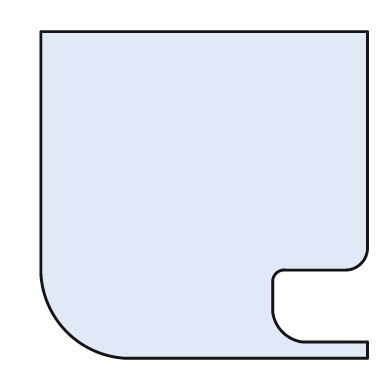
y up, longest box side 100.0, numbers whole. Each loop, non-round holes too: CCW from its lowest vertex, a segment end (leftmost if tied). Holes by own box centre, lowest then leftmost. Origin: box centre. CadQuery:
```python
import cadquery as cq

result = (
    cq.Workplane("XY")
    .moveTo(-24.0, -50.0)
    .lineTo(50.0, -50.0)
    .lineTo(50.0, -45.0)
    .lineTo(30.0, -45.0)
    .threePointArc((24.0, -42.0), (21.0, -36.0))
    .lineTo(21.0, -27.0)
    .threePointArc((22.0, -24.0), (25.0, -23.0))
    .lineTo(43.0, -23.0)
    .threePointArc((48.0, -21.0), (50.0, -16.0))
    .lineTo(50.0, 50.0)
    .lineTo(-50.0, 50.0)
    .lineTo(-50.0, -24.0)
    .threePointArc((-42.0, -42.0), (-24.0, -50.0))
    .close()
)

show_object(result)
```